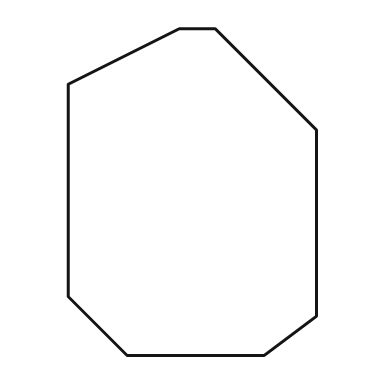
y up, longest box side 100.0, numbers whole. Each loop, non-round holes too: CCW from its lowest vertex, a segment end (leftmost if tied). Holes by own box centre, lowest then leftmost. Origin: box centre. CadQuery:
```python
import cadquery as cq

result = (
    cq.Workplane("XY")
    .moveTo(-20.0, -50.0)
    .lineTo(22.0, -50.0)
    .lineTo(38.0, -38.0)
    .lineTo(38.0, 19.0)
    .lineTo(7.0, 50.0)
    .lineTo(-4.0, 50.0)
    .lineTo(-38.0, 33.0)
    .lineTo(-38.0, -32.0)
    .close()
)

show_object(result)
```